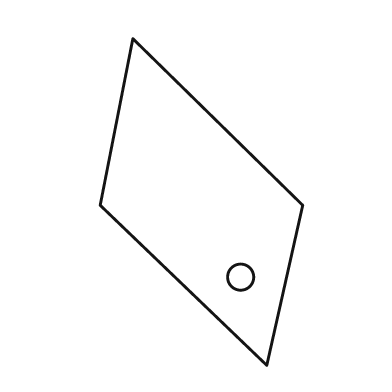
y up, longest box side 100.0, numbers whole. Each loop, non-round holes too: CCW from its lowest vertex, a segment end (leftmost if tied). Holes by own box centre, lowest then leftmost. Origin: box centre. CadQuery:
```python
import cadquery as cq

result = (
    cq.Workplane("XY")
    .moveTo(20.0, -50.0)
    .lineTo(31.0, -1.0)
    .lineTo(-21.0, 50.0)
    .lineTo(-31.0, -1.0)
    .close()
    .moveTo(12.0, -23.0)
    .circle(4.0)
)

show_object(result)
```